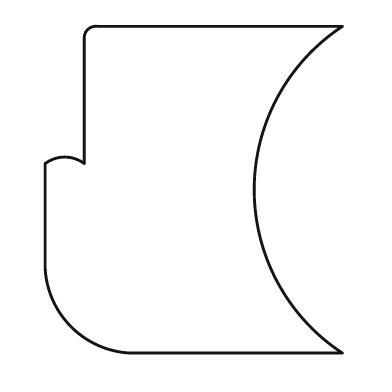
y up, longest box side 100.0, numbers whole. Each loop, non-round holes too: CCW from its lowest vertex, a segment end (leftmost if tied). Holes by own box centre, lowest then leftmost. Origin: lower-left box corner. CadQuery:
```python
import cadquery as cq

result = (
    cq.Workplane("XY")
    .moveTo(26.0, 0.0)
    .lineTo(91.0, 0.0)
    .threePointArc((64.0, 50.0), (91.0, 100.0))
    .lineTo(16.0, 100.0)
    .threePointArc((13.0, 99.0), (12.0, 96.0))
    .lineTo(12.0, 58.0)
    .threePointArc((6.0, 60.0), (0.0, 58.0))
    .lineTo(0.0, 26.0)
    .threePointArc((8.0, 8.0), (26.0, 0.0))
    .close()
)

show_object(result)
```